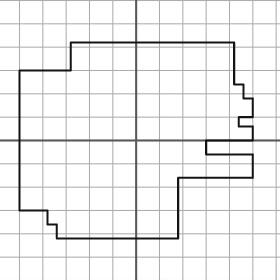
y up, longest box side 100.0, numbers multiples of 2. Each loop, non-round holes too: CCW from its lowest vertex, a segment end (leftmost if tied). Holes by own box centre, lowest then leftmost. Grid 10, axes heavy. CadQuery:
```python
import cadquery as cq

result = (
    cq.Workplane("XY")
    .moveTo(-34.0, -42.0)
    .lineTo(18.0, -42.0)
    .lineTo(18.0, -16.0)
    .lineTo(50.0, -16.0)
    .lineTo(50.0, -6.0)
    .lineTo(30.0, -6.0)
    .lineTo(30.0, 0.0)
    .lineTo(50.0, 0.0)
    .lineTo(50.0, 6.0)
    .lineTo(44.0, 6.0)
    .lineTo(44.0, 10.0)
    .lineTo(50.0, 10.0)
    .lineTo(50.0, 18.0)
    .lineTo(46.0, 18.0)
    .lineTo(46.0, 24.0)
    .lineTo(42.0, 24.0)
    .lineTo(42.0, 42.0)
    .lineTo(-28.0, 42.0)
    .lineTo(-28.0, 30.0)
    .lineTo(-50.0, 30.0)
    .lineTo(-50.0, -30.0)
    .lineTo(-38.0, -30.0)
    .lineTo(-38.0, -36.0)
    .lineTo(-34.0, -36.0)
    .close()
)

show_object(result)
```